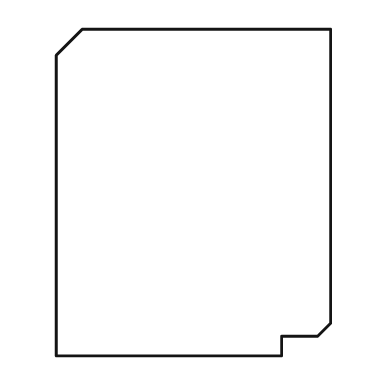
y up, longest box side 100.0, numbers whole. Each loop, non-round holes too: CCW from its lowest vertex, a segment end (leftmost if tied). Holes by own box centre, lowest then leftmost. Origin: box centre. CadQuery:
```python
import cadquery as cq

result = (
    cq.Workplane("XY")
    .moveTo(-42.0, -50.0)
    .lineTo(27.0, -50.0)
    .lineTo(27.0, -44.0)
    .lineTo(38.0, -44.0)
    .lineTo(42.0, -40.0)
    .lineTo(42.0, 50.0)
    .lineTo(-34.0, 50.0)
    .lineTo(-42.0, 42.0)
    .close()
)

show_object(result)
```